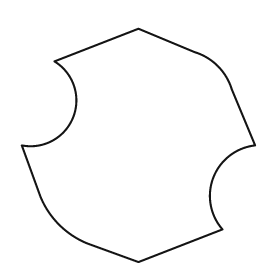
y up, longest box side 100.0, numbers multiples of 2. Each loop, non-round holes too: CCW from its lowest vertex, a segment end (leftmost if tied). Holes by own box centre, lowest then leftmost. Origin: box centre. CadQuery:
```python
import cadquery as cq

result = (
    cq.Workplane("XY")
    .moveTo(0.0, -50.0)
    .lineTo(36.0, -36.0)
    .threePointArc((32.0, -14.0), (50.0, 0.0))
    .lineTo(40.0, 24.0)
    .threePointArc((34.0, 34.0), (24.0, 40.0))
    .lineTo(0.0, 50.0)
    .lineTo(-36.0, 36.0)
    .threePointArc((-28.0, 12.0), (-50.0, 0.0))
    .lineTo(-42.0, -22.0)
    .threePointArc((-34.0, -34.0), (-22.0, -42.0))
    .close()
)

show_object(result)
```